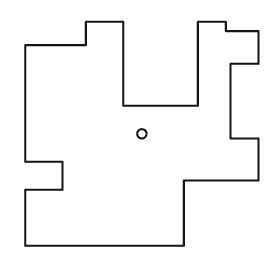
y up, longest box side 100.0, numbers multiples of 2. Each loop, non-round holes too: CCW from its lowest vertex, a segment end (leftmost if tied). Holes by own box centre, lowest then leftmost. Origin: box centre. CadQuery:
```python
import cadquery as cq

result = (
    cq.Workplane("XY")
    .moveTo(-50.0, -48.0)
    .lineTo(18.0, -48.0)
    .lineTo(18.0, -20.0)
    .lineTo(50.0, -20.0)
    .lineTo(50.0, -2.0)
    .lineTo(38.0, -2.0)
    .lineTo(38.0, 30.0)
    .lineTo(50.0, 30.0)
    .lineTo(50.0, 44.0)
    .lineTo(36.0, 44.0)
    .lineTo(36.0, 48.0)
    .lineTo(24.0, 48.0)
    .lineTo(24.0, 12.0)
    .lineTo(-8.0, 12.0)
    .lineTo(-8.0, 48.0)
    .lineTo(-24.0, 48.0)
    .lineTo(-24.0, 38.0)
    .lineTo(-50.0, 38.0)
    .lineTo(-50.0, -12.0)
    .lineTo(-34.0, -12.0)
    .lineTo(-34.0, -24.0)
    .lineTo(-50.0, -24.0)
    .close()
    .moveTo(0.0, 0.0)
    .circle(2.0)
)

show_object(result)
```